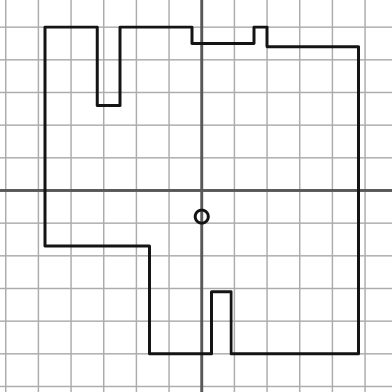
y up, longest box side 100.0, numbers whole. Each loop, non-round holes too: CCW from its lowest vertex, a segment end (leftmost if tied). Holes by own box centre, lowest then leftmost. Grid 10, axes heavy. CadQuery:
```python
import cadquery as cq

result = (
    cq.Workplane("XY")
    .moveTo(-16.0, -50.0)
    .lineTo(3.0, -50.0)
    .lineTo(3.0, -31.0)
    .lineTo(9.0, -31.0)
    .lineTo(9.0, -50.0)
    .lineTo(48.0, -50.0)
    .lineTo(48.0, 44.0)
    .lineTo(20.0, 44.0)
    .lineTo(20.0, 50.0)
    .lineTo(16.0, 50.0)
    .lineTo(16.0, 45.0)
    .lineTo(-3.0, 45.0)
    .lineTo(-3.0, 50.0)
    .lineTo(-25.0, 50.0)
    .lineTo(-25.0, 26.0)
    .lineTo(-32.0, 26.0)
    .lineTo(-32.0, 50.0)
    .lineTo(-48.0, 50.0)
    .lineTo(-48.0, -17.0)
    .lineTo(-16.0, -17.0)
    .close()
    .moveTo(0.0, -8.0)
    .circle(2.0)
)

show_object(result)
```